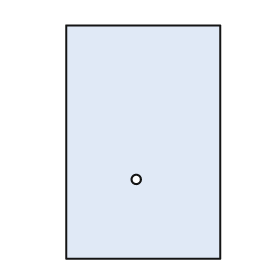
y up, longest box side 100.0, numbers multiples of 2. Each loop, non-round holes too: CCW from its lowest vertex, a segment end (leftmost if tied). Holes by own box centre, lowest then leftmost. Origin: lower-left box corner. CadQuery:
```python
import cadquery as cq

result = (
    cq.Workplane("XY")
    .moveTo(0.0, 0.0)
    .lineTo(66.0, 0.0)
    .lineTo(66.0, 100.0)
    .lineTo(0.0, 100.0)
    .close()
    .moveTo(30.0, 34.0)
    .circle(2.0)
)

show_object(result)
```